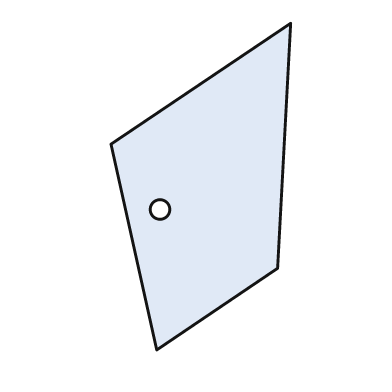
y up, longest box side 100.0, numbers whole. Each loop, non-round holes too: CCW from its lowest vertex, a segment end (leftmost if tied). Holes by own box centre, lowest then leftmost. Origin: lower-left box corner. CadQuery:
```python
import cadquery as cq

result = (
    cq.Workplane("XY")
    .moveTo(14.0, 0.0)
    .lineTo(51.0, 25.0)
    .lineTo(55.0, 100.0)
    .lineTo(0.0, 63.0)
    .close()
    .moveTo(15.0, 43.0)
    .circle(3.0)
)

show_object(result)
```